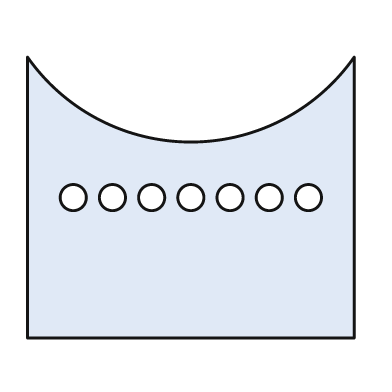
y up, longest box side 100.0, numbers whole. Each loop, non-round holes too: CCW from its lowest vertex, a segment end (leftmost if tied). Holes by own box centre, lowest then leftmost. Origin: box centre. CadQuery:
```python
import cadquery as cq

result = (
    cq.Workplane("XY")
    .moveTo(-50.0, -43.0)
    .lineTo(50.0, -43.0)
    .lineTo(50.0, 43.0)
    .threePointArc((0.0, 17.0), (-50.0, 43.0))
    .close()
    .moveTo(-36.0, 0.0)
    .circle(4.0)
    .moveTo(-24.0, 0.0)
    .circle(4.0)
    .moveTo(-12.0, 0.0)
    .circle(4.0)
    .moveTo(0.0, 0.0)
    .circle(4.0)
    .moveTo(12.0, 0.0)
    .circle(4.0)
    .moveTo(24.0, 0.0)
    .circle(4.0)
    .moveTo(36.0, 0.0)
    .circle(4.0)
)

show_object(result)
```